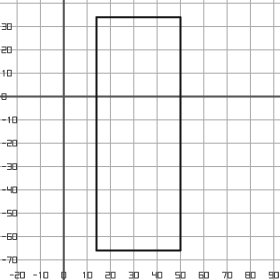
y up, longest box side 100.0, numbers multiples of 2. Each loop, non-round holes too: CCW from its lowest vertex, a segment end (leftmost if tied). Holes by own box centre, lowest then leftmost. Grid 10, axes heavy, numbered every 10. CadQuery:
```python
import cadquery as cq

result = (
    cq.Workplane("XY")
    .moveTo(14.0, -66.0)
    .lineTo(50.0, -66.0)
    .lineTo(50.0, 34.0)
    .lineTo(14.0, 34.0)
    .close()
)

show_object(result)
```